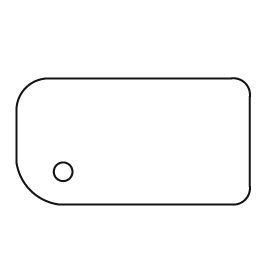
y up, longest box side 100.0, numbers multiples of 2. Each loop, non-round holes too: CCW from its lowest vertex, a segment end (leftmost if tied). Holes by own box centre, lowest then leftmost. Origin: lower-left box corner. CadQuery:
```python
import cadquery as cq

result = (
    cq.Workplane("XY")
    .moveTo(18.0, 0.0)
    .lineTo(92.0, 0.0)
    .threePointArc((98.0, 2.0), (100.0, 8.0))
    .lineTo(100.0, 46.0)
    .threePointArc((98.0, 52.0), (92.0, 54.0))
    .lineTo(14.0, 54.0)
    .threePointArc((4.0, 50.0), (0.0, 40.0))
    .lineTo(0.0, 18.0)
    .threePointArc((6.0, 6.0), (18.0, 0.0))
    .close()
    .moveTo(20.0, 14.0)
    .circle(4.0)
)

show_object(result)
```